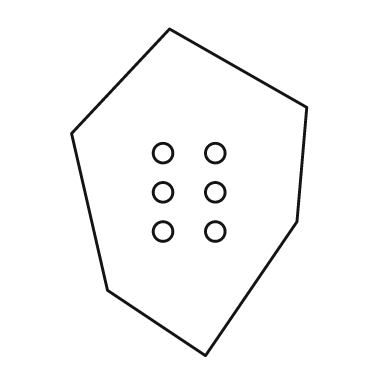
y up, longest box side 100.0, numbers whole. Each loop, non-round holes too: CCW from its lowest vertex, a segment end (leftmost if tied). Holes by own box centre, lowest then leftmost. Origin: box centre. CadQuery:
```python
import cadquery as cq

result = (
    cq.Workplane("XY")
    .moveTo(5.0, -50.0)
    .lineTo(33.0, -9.0)
    .lineTo(36.0, 26.0)
    .lineTo(-6.0, 50.0)
    .lineTo(-36.0, 18.0)
    .lineTo(-25.0, -30.0)
    .close()
    .moveTo(-8.0, -12.0)
    .circle(3.0)
    .moveTo(8.0, -12.0)
    .circle(3.0)
    .moveTo(-8.0, 0.0)
    .circle(3.0)
    .moveTo(8.0, 0.0)
    .circle(3.0)
    .moveTo(-8.0, 12.0)
    .circle(3.0)
    .moveTo(8.0, 12.0)
    .circle(3.0)
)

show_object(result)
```